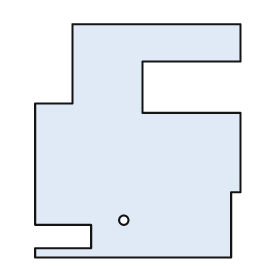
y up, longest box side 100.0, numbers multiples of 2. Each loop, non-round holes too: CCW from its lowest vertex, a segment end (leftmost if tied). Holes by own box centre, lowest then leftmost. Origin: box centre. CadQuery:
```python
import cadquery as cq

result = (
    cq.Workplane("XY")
    .moveTo(-44.0, -50.0)
    .lineTo(40.0, -50.0)
    .lineTo(40.0, -22.0)
    .lineTo(44.0, -22.0)
    .lineTo(44.0, 12.0)
    .lineTo(2.0, 12.0)
    .lineTo(2.0, 34.0)
    .lineTo(44.0, 34.0)
    .lineTo(44.0, 50.0)
    .lineTo(-28.0, 50.0)
    .lineTo(-28.0, 16.0)
    .lineTo(-44.0, 16.0)
    .lineTo(-44.0, -36.0)
    .lineTo(-20.0, -36.0)
    .lineTo(-20.0, -46.0)
    .lineTo(-44.0, -46.0)
    .close()
    .moveTo(-6.0, -34.0)
    .circle(2.0)
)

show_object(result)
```